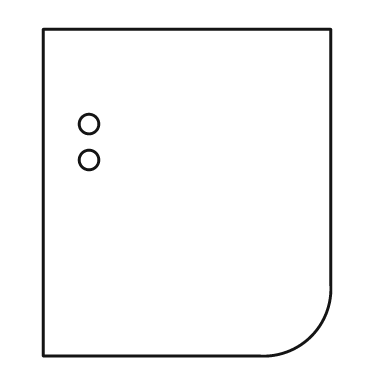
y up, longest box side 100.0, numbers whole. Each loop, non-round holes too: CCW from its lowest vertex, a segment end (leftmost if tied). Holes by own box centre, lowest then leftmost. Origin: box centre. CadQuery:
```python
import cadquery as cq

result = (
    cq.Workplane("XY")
    .moveTo(-44.0, -50.0)
    .lineTo(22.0, -50.0)
    .threePointArc((38.0, -44.0), (44.0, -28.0))
    .lineTo(44.0, 50.0)
    .lineTo(-44.0, 50.0)
    .close()
    .moveTo(-30.0, 10.0)
    .circle(3.0)
    .moveTo(-30.0, 21.0)
    .circle(3.0)
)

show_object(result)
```